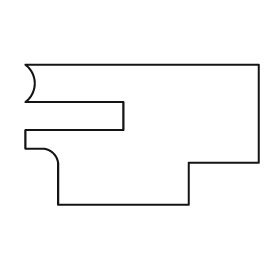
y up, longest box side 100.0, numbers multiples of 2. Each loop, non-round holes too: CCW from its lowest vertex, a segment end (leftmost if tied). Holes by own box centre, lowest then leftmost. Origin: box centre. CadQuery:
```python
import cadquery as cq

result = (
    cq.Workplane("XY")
    .moveTo(-36.0, -30.0)
    .lineTo(20.0, -30.0)
    .lineTo(20.0, -12.0)
    .lineTo(50.0, -12.0)
    .lineTo(50.0, 30.0)
    .lineTo(-50.0, 30.0)
    .threePointArc((-46.0, 22.0), (-50.0, 14.0))
    .lineTo(-8.0, 14.0)
    .lineTo(-8.0, 2.0)
    .lineTo(-50.0, 2.0)
    .lineTo(-50.0, -6.0)
    .lineTo(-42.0, -6.0)
    .threePointArc((-38.0, -8.0), (-36.0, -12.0))
    .close()
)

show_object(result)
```